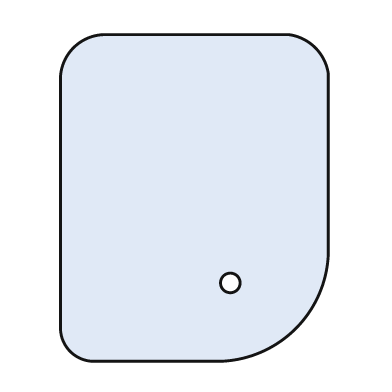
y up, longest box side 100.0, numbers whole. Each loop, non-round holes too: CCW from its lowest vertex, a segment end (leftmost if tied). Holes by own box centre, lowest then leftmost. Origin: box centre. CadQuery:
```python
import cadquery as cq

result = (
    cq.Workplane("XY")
    .moveTo(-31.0, -50.0)
    .lineTo(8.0, -50.0)
    .threePointArc((31.0, -40.0), (41.0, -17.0))
    .lineTo(41.0, 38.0)
    .threePointArc((37.0, 46.0), (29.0, 50.0))
    .lineTo(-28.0, 50.0)
    .threePointArc((-37.0, 46.0), (-41.0, 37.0))
    .lineTo(-41.0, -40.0)
    .threePointArc((-38.0, -47.0), (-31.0, -50.0))
    .close()
    .moveTo(11.0, -26.0)
    .circle(3.0)
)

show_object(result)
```